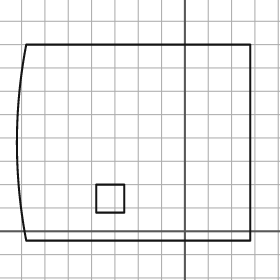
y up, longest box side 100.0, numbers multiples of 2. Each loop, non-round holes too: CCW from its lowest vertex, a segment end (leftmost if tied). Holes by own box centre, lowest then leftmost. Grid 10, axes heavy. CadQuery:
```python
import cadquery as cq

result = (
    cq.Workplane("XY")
    .moveTo(-68.0, -4.0)
    .lineTo(28.0, -4.0)
    .lineTo(28.0, 80.0)
    .lineTo(-68.0, 80.0)
    .threePointArc((-72.0, 38.0), (-68.0, -4.0))
    .close()
    .moveTo(-38.0, 8.0)
    .lineTo(-26.0, 8.0)
    .lineTo(-26.0, 20.0)
    .lineTo(-38.0, 20.0)
    .close()
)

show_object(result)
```